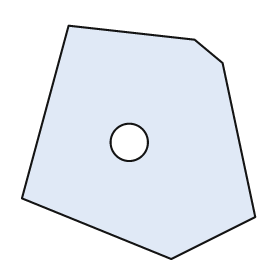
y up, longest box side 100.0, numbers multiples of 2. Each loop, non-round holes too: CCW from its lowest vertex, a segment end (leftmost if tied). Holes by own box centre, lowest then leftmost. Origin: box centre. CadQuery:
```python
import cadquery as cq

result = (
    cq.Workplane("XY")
    .moveTo(14.0, -50.0)
    .lineTo(50.0, -32.0)
    .lineTo(36.0, 34.0)
    .lineTo(24.0, 44.0)
    .lineTo(-30.0, 50.0)
    .lineTo(-50.0, -24.0)
    .close()
    .moveTo(-4.0, 0.0)
    .circle(8.0)
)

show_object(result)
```